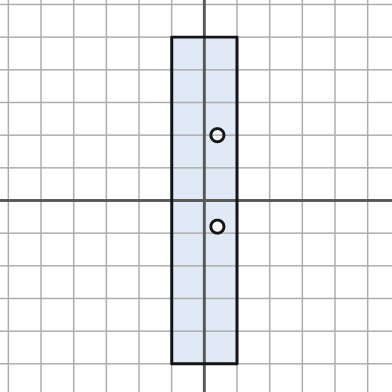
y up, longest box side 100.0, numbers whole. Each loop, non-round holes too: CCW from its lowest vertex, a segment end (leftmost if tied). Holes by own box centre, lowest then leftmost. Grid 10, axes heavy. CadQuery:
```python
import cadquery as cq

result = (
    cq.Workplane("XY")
    .moveTo(-10.0, -50.0)
    .lineTo(10.0, -50.0)
    .lineTo(10.0, 50.0)
    .lineTo(-10.0, 50.0)
    .close()
    .moveTo(4.0, -8.0)
    .circle(2.0)
    .moveTo(4.0, 20.0)
    .circle(2.0)
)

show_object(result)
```